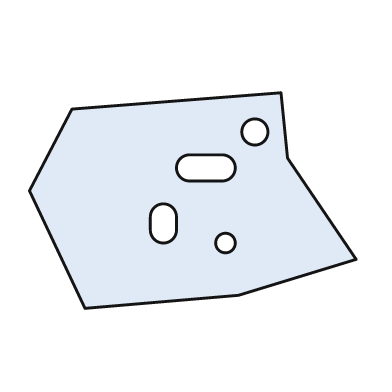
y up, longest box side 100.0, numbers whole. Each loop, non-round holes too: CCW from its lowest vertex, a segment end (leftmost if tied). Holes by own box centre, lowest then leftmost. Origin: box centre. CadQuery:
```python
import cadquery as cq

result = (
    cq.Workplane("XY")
    .moveTo(-33.0, -33.0)
    .lineTo(14.0, -29.0)
    .lineTo(50.0, -18.0)
    .lineTo(29.0, 13.0)
    .lineTo(27.0, 33.0)
    .lineTo(-37.0, 28.0)
    .lineTo(-50.0, 3.0)
    .close()
    .moveTo(10.0, -13.0)
    .circle(3.0)
    .moveTo(-13.0, -9.0)
    .threePointArc((-9.0, -13.0), (-5.0, -9.0))
    .lineTo(-5.0, -5.0)
    .threePointArc((-9.0, -1.0), (-13.0, -5.0))
    .close()
    .moveTo(-1.0, 6.0)
    .lineTo(9.0, 6.0)
    .threePointArc((13.0, 10.0), (9.0, 14.0))
    .lineTo(-1.0, 14.0)
    .threePointArc((-5.0, 10.0), (-1.0, 6.0))
    .close()
    .moveTo(19.0, 21.0)
    .circle(4.0)
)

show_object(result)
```